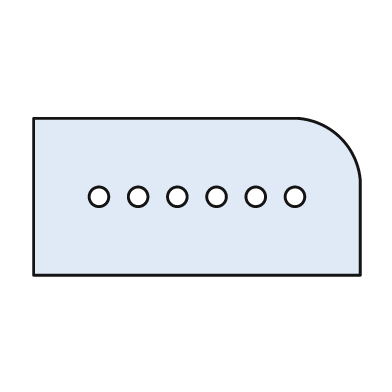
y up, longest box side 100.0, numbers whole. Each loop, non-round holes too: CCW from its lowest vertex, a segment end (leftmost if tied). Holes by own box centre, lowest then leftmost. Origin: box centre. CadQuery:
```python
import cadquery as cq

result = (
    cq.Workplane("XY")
    .moveTo(-50.0, -24.0)
    .lineTo(50.0, -24.0)
    .lineTo(50.0, 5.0)
    .threePointArc((44.0, 18.0), (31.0, 24.0))
    .lineTo(-50.0, 24.0)
    .close()
    .moveTo(-30.0, 0.0)
    .circle(3.0)
    .moveTo(-18.0, 0.0)
    .circle(3.0)
    .moveTo(-6.0, 0.0)
    .circle(3.0)
    .moveTo(6.0, 0.0)
    .circle(3.0)
    .moveTo(18.0, 0.0)
    .circle(3.0)
    .moveTo(30.0, 0.0)
    .circle(3.0)
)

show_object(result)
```